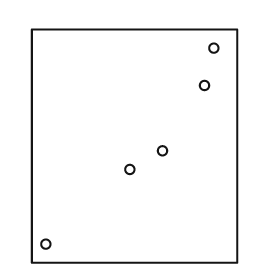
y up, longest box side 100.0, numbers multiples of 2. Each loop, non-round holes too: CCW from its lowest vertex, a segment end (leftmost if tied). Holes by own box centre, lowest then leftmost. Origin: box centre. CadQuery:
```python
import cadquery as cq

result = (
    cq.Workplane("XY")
    .moveTo(-44.0, -50.0)
    .lineTo(44.0, -50.0)
    .lineTo(44.0, 50.0)
    .lineTo(-44.0, 50.0)
    .close()
    .moveTo(-38.0, -42.0)
    .circle(2.0)
    .moveTo(-2.0, -10.0)
    .circle(2.0)
    .moveTo(12.0, -2.0)
    .circle(2.0)
    .moveTo(30.0, 26.0)
    .circle(2.0)
    .moveTo(34.0, 42.0)
    .circle(2.0)
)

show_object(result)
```